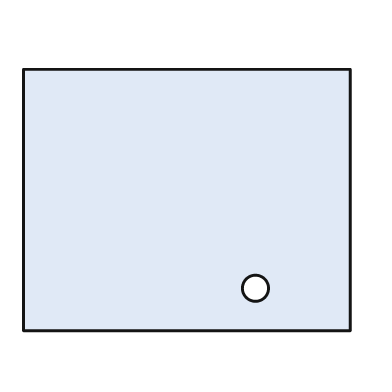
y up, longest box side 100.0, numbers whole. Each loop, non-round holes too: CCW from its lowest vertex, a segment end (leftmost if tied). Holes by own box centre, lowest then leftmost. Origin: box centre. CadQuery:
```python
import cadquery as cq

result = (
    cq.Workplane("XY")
    .moveTo(-50.0, -40.0)
    .lineTo(50.0, -40.0)
    .lineTo(50.0, 40.0)
    .lineTo(-50.0, 40.0)
    .close()
    .moveTo(21.0, -27.0)
    .circle(4.0)
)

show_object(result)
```